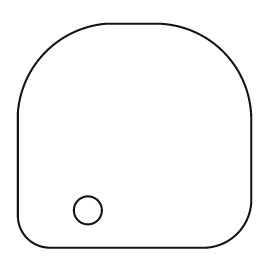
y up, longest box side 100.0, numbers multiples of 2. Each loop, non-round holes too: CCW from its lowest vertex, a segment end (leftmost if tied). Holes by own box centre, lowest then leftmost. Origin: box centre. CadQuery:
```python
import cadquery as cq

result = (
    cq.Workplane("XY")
    .moveTo(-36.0, -48.0)
    .lineTo(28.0, -48.0)
    .threePointArc((44.0, -42.0), (50.0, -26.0))
    .lineTo(50.0, 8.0)
    .threePointArc((38.0, 36.0), (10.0, 48.0))
    .lineTo(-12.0, 48.0)
    .threePointArc((-38.0, 36.0), (-50.0, 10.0))
    .lineTo(-50.0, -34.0)
    .threePointArc((-46.0, -44.0), (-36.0, -48.0))
    .close()
    .moveTo(-20.0, -32.0)
    .circle(6.0)
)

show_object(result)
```